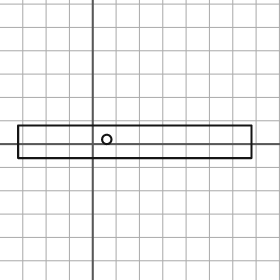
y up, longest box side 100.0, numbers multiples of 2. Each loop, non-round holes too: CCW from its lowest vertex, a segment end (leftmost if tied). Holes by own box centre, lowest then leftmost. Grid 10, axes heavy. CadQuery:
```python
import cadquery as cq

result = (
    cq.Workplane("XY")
    .moveTo(-32.0, -6.0)
    .lineTo(68.0, -6.0)
    .lineTo(68.0, 8.0)
    .lineTo(-32.0, 8.0)
    .close()
    .moveTo(6.0, 2.0)
    .circle(2.0)
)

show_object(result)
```